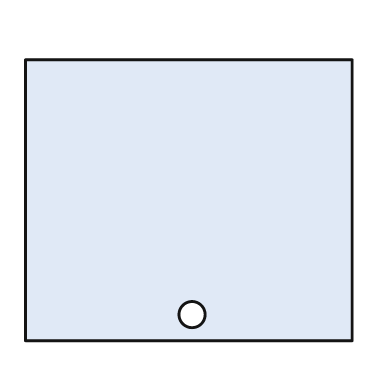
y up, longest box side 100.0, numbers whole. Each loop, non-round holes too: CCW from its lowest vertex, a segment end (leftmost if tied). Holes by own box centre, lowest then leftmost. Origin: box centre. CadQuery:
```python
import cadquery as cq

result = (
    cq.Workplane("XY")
    .moveTo(-50.0, -43.0)
    .lineTo(50.0, -43.0)
    .lineTo(50.0, 43.0)
    .lineTo(-50.0, 43.0)
    .close()
    .moveTo(1.0, -35.0)
    .circle(4.0)
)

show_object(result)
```